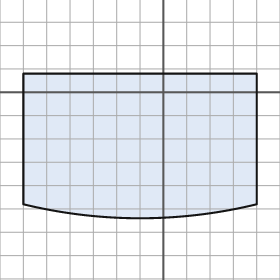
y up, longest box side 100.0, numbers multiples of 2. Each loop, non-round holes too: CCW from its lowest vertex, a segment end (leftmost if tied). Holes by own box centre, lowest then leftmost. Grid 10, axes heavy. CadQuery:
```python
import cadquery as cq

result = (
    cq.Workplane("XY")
    .moveTo(-60.0, -48.0)
    .threePointArc((-10.0, -54.0), (40.0, -48.0))
    .lineTo(40.0, 8.0)
    .lineTo(-60.0, 8.0)
    .close()
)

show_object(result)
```